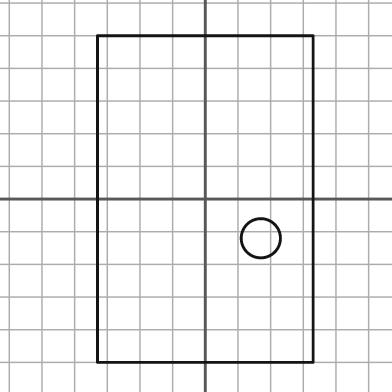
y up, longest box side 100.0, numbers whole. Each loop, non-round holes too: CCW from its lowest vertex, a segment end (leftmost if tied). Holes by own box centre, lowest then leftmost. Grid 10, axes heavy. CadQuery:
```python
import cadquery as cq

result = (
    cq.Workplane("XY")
    .moveTo(-33.0, -50.0)
    .lineTo(33.0, -50.0)
    .lineTo(33.0, 50.0)
    .lineTo(-33.0, 50.0)
    .close()
    .moveTo(17.0, -12.0)
    .circle(6.0)
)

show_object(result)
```